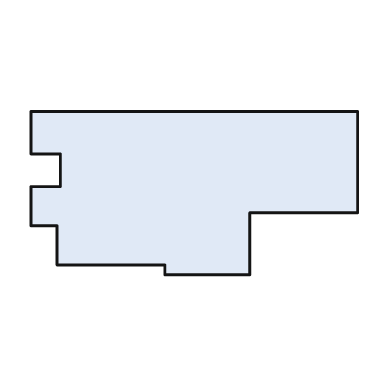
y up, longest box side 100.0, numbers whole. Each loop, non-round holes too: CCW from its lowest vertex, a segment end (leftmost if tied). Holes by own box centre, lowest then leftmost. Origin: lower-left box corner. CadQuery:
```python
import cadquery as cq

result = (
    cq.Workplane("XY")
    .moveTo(41.0, 0.0)
    .lineTo(67.0, 0.0)
    .lineTo(67.0, 19.0)
    .lineTo(100.0, 19.0)
    .lineTo(100.0, 50.0)
    .lineTo(0.0, 50.0)
    .lineTo(0.0, 37.0)
    .lineTo(9.0, 37.0)
    .lineTo(9.0, 27.0)
    .lineTo(0.0, 27.0)
    .lineTo(0.0, 15.0)
    .lineTo(8.0, 15.0)
    .lineTo(8.0, 3.0)
    .lineTo(41.0, 3.0)
    .close()
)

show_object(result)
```